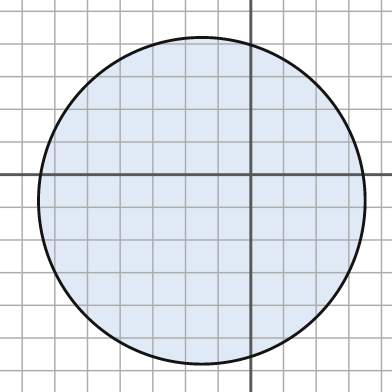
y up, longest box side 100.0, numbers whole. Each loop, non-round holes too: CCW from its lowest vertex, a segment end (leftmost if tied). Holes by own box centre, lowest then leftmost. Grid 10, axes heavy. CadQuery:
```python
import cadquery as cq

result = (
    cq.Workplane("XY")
    .moveTo(-15.0, -8.0)
    .circle(50.0)
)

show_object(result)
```